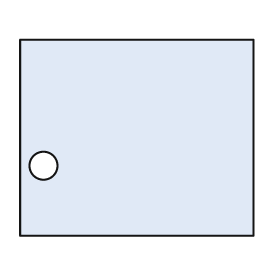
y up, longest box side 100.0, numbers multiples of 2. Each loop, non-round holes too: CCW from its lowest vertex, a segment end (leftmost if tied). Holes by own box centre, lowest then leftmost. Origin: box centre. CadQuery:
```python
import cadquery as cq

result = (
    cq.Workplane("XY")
    .moveTo(-50.0, -42.0)
    .lineTo(50.0, -42.0)
    .lineTo(50.0, 42.0)
    .lineTo(-50.0, 42.0)
    .close()
    .moveTo(-40.0, -12.0)
    .circle(6.0)
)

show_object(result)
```